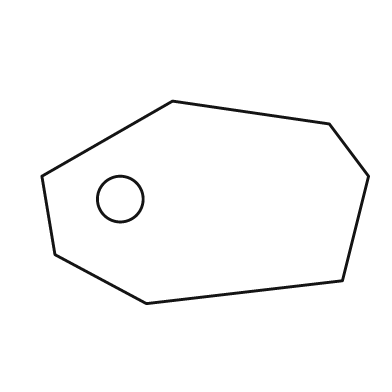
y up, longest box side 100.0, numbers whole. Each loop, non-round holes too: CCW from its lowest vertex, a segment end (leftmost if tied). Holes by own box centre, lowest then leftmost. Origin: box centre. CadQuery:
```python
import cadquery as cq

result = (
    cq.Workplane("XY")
    .moveTo(-18.0, -31.0)
    .lineTo(42.0, -24.0)
    .lineTo(50.0, 8.0)
    .lineTo(38.0, 24.0)
    .lineTo(-10.0, 31.0)
    .lineTo(-50.0, 8.0)
    .lineTo(-46.0, -16.0)
    .close()
    .moveTo(-26.0, 1.0)
    .circle(7.0)
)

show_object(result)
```